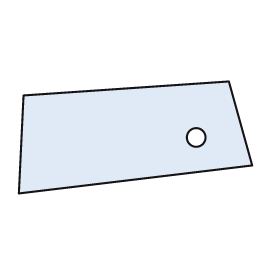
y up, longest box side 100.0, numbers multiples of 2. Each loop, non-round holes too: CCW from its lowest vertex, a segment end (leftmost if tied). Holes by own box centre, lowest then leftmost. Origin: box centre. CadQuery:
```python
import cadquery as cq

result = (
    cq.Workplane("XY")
    .moveTo(-50.0, -24.0)
    .lineTo(50.0, -12.0)
    .lineTo(40.0, 24.0)
    .lineTo(-48.0, 18.0)
    .close()
    .moveTo(26.0, 0.0)
    .circle(4.0)
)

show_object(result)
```